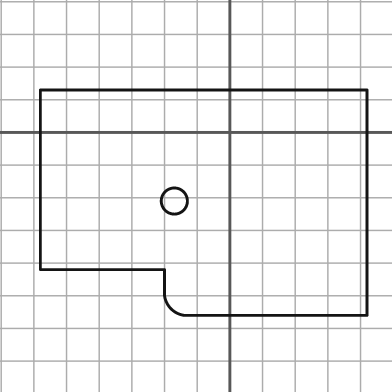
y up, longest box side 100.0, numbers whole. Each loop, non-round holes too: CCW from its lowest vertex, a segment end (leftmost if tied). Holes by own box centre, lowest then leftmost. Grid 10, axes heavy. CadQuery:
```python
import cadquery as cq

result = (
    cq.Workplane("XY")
    .moveTo(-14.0, -56.0)
    .lineTo(42.0, -56.0)
    .lineTo(42.0, 13.0)
    .lineTo(-58.0, 13.0)
    .lineTo(-58.0, -42.0)
    .lineTo(-20.0, -42.0)
    .lineTo(-20.0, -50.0)
    .threePointArc((-18.0, -54.0), (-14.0, -56.0))
    .close()
    .moveTo(-17.0, -21.0)
    .circle(4.0)
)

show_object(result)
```